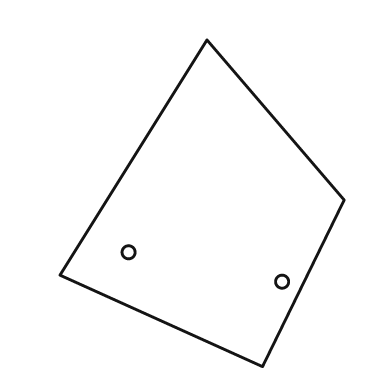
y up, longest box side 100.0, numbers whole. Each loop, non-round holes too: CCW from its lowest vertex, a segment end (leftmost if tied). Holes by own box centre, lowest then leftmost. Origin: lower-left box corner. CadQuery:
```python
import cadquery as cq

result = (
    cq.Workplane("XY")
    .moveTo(62.0, 0.0)
    .lineTo(87.0, 51.0)
    .lineTo(45.0, 100.0)
    .lineTo(0.0, 28.0)
    .close()
    .moveTo(68.0, 26.0)
    .circle(2.0)
    .moveTo(21.0, 35.0)
    .circle(2.0)
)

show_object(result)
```